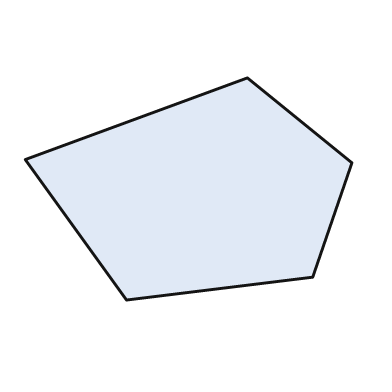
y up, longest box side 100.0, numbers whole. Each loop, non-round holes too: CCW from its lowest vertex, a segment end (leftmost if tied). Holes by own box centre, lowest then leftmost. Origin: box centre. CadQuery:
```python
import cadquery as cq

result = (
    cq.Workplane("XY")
    .moveTo(-19.0, -34.0)
    .lineTo(38.0, -27.0)
    .lineTo(50.0, 8.0)
    .lineTo(18.0, 34.0)
    .lineTo(-50.0, 9.0)
    .close()
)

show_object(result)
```